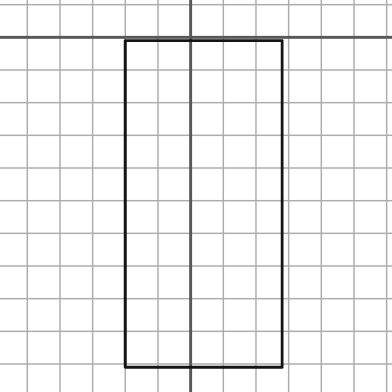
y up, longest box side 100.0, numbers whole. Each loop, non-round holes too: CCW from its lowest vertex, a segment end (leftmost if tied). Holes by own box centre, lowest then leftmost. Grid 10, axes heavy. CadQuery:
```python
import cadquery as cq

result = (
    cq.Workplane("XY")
    .moveTo(-20.0, -101.0)
    .lineTo(28.0, -101.0)
    .lineTo(28.0, -1.0)
    .lineTo(-20.0, -1.0)
    .close()
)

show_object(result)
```